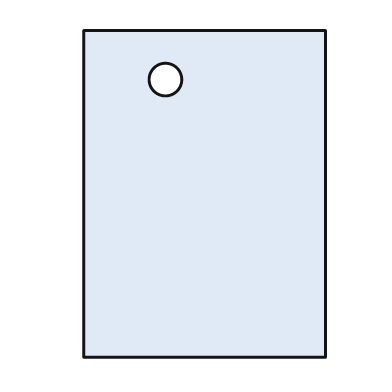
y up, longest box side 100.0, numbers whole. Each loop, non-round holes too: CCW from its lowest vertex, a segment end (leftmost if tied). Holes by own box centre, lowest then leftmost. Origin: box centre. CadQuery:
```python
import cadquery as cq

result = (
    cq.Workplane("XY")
    .moveTo(-37.0, -50.0)
    .lineTo(37.0, -50.0)
    .lineTo(37.0, 50.0)
    .lineTo(-37.0, 50.0)
    .close()
    .moveTo(-12.0, 35.0)
    .circle(5.0)
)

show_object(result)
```